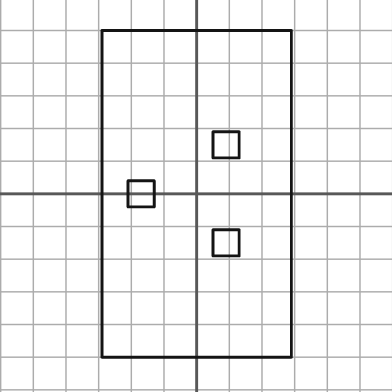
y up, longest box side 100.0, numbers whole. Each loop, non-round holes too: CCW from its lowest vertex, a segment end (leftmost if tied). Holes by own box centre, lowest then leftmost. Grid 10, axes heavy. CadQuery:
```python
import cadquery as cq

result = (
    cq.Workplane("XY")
    .moveTo(-29.0, -50.0)
    .lineTo(29.0, -50.0)
    .lineTo(29.0, 50.0)
    .lineTo(-29.0, 50.0)
    .close()
    .moveTo(5.0, -19.0)
    .lineTo(13.0, -19.0)
    .lineTo(13.0, -11.0)
    .lineTo(5.0, -11.0)
    .close()
    .moveTo(-21.0, -4.0)
    .lineTo(-13.0, -4.0)
    .lineTo(-13.0, 4.0)
    .lineTo(-21.0, 4.0)
    .close()
    .moveTo(5.0, 11.0)
    .lineTo(13.0, 11.0)
    .lineTo(13.0, 19.0)
    .lineTo(5.0, 19.0)
    .close()
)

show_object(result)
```